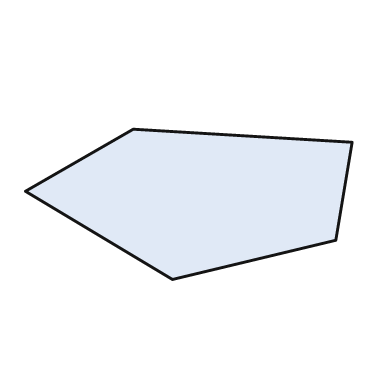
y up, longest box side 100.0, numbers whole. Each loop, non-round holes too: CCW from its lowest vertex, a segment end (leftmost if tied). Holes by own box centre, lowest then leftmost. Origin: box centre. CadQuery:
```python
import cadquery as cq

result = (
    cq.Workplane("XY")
    .moveTo(-5.0, -23.0)
    .lineTo(45.0, -11.0)
    .lineTo(50.0, 19.0)
    .lineTo(-17.0, 23.0)
    .lineTo(-50.0, 4.0)
    .close()
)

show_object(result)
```